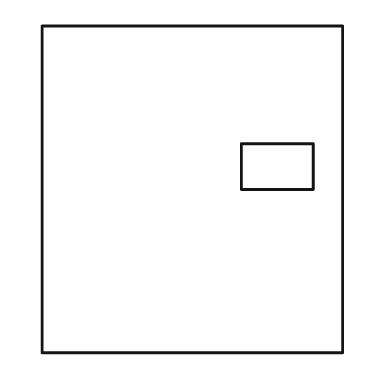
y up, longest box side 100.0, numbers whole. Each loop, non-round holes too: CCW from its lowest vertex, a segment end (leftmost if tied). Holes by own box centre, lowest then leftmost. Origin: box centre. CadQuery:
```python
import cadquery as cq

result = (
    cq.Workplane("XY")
    .moveTo(-46.0, -50.0)
    .lineTo(46.0, -50.0)
    .lineTo(46.0, 50.0)
    .lineTo(-46.0, 50.0)
    .close()
    .moveTo(15.0, 0.0)
    .lineTo(37.0, 0.0)
    .lineTo(37.0, 14.0)
    .lineTo(15.0, 14.0)
    .close()
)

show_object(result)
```